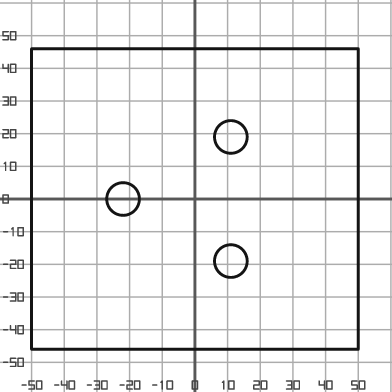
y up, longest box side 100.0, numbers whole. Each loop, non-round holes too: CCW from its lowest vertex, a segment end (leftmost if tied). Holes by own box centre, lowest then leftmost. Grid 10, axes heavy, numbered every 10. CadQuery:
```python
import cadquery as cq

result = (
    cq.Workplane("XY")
    .moveTo(-50.0, -46.0)
    .lineTo(50.0, -46.0)
    .lineTo(50.0, 46.0)
    .lineTo(-50.0, 46.0)
    .close()
    .moveTo(11.0, -19.0)
    .circle(5.0)
    .moveTo(-22.0, 0.0)
    .circle(5.0)
    .moveTo(11.0, 19.0)
    .circle(5.0)
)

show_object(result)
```